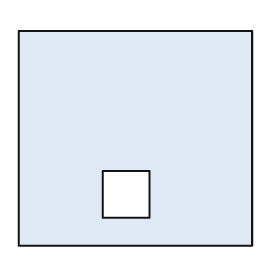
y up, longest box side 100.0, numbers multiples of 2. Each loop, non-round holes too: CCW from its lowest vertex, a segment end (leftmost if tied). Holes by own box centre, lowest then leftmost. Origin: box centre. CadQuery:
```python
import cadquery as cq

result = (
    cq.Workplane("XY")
    .moveTo(-50.0, -46.0)
    .lineTo(50.0, -46.0)
    .lineTo(50.0, 46.0)
    .lineTo(-50.0, 46.0)
    .close()
    .moveTo(-14.0, -34.0)
    .lineTo(6.0, -34.0)
    .lineTo(6.0, -14.0)
    .lineTo(-14.0, -14.0)
    .close()
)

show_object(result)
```